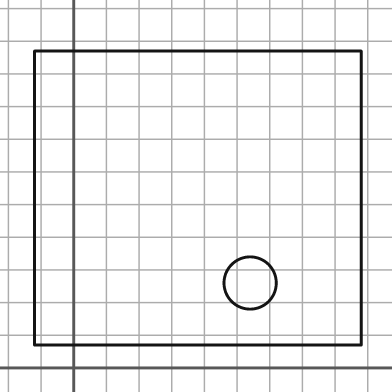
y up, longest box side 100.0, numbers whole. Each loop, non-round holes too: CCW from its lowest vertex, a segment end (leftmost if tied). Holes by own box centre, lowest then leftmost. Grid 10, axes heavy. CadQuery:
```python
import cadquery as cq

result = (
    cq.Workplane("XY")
    .moveTo(-12.0, 7.0)
    .lineTo(88.0, 7.0)
    .lineTo(88.0, 97.0)
    .lineTo(-12.0, 97.0)
    .close()
    .moveTo(54.0, 26.0)
    .circle(8.0)
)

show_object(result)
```